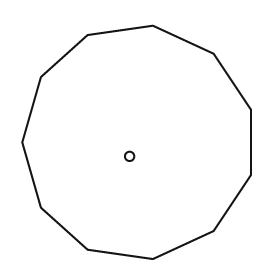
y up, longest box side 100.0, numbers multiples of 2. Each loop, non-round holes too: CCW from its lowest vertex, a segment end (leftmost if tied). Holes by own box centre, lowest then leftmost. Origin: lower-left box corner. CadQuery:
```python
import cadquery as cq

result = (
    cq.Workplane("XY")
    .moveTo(56.0, 0.0)
    .lineTo(82.0, 12.0)
    .lineTo(98.0, 36.0)
    .lineTo(98.0, 64.0)
    .lineTo(82.0, 88.0)
    .lineTo(56.0, 100.0)
    .lineTo(28.0, 96.0)
    .lineTo(8.0, 78.0)
    .lineTo(0.0, 50.0)
    .lineTo(8.0, 22.0)
    .lineTo(28.0, 4.0)
    .close()
    .moveTo(46.0, 44.0)
    .circle(2.0)
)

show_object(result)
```